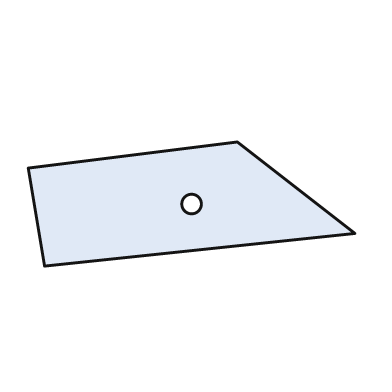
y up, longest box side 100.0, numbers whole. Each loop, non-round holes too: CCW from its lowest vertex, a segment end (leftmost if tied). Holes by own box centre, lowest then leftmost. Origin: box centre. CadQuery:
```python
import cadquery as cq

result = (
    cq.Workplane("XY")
    .moveTo(-45.0, -19.0)
    .lineTo(50.0, -9.0)
    .lineTo(14.0, 19.0)
    .lineTo(-50.0, 11.0)
    .close()
    .moveTo(0.0, 0.0)
    .circle(3.0)
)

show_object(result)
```